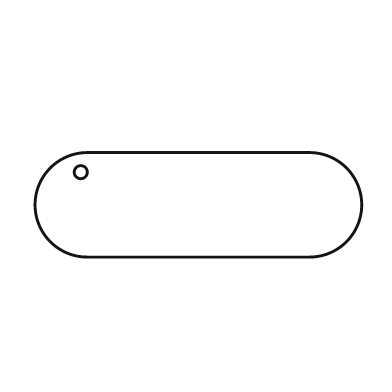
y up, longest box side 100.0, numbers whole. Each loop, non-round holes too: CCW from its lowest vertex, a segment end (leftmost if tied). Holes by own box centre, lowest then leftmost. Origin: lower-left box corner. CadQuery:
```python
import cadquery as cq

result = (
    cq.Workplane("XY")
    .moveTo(16.0, 0.0)
    .lineTo(84.0, 0.0)
    .threePointArc((100.0, 16.0), (84.0, 32.0))
    .lineTo(16.0, 32.0)
    .threePointArc((0.0, 16.0), (16.0, 0.0))
    .close()
    .moveTo(14.0, 26.0)
    .circle(2.0)
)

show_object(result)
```